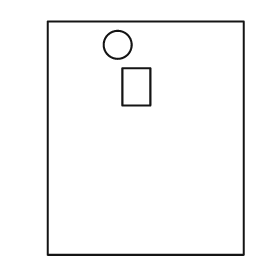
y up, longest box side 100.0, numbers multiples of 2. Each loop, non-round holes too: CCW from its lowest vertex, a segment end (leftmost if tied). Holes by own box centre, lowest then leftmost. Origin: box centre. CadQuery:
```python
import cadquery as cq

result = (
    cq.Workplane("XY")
    .moveTo(-42.0, -50.0)
    .lineTo(42.0, -50.0)
    .lineTo(42.0, 50.0)
    .lineTo(-42.0, 50.0)
    .close()
    .moveTo(-10.0, 14.0)
    .lineTo(2.0, 14.0)
    .lineTo(2.0, 30.0)
    .lineTo(-10.0, 30.0)
    .close()
    .moveTo(-12.0, 40.0)
    .circle(6.0)
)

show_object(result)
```